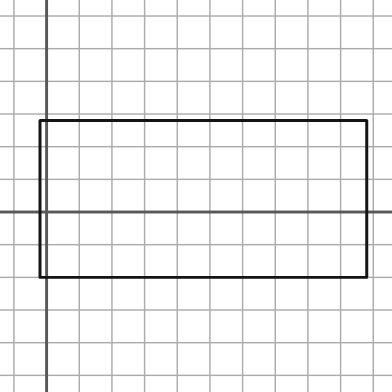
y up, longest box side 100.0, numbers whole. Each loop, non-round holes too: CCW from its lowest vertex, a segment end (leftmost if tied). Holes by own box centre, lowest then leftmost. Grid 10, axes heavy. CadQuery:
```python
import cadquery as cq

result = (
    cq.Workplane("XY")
    .moveTo(-2.0, -20.0)
    .lineTo(98.0, -20.0)
    .lineTo(98.0, 28.0)
    .lineTo(-2.0, 28.0)
    .close()
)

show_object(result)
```